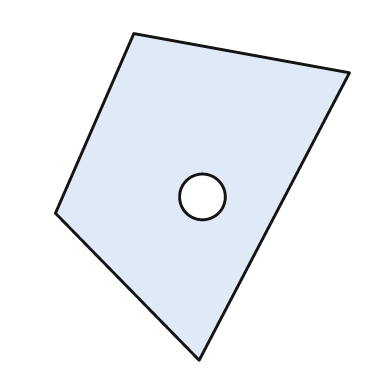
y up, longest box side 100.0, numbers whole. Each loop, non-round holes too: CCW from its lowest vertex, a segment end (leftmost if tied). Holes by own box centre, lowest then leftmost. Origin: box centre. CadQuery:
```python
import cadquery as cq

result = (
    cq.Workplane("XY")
    .moveTo(-1.0, -50.0)
    .lineTo(45.0, 38.0)
    .lineTo(-21.0, 50.0)
    .lineTo(-45.0, -5.0)
    .close()
    .moveTo(0.0, 0.0)
    .circle(7.0)
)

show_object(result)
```